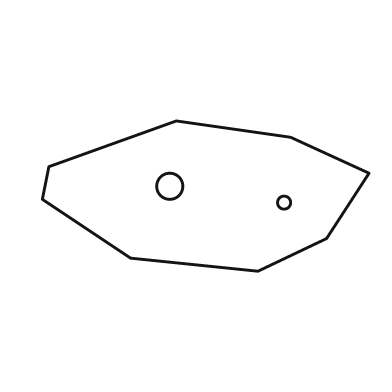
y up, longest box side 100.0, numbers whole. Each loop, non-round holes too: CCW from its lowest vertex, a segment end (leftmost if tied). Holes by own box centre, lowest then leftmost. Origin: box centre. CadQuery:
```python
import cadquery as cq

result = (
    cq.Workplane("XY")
    .moveTo(16.0, -23.0)
    .lineTo(37.0, -13.0)
    .lineTo(50.0, 7.0)
    .lineTo(26.0, 18.0)
    .lineTo(-9.0, 23.0)
    .lineTo(-48.0, 9.0)
    .lineTo(-50.0, -1.0)
    .lineTo(-23.0, -19.0)
    .close()
    .moveTo(24.0, -2.0)
    .circle(2.0)
    .moveTo(-11.0, 3.0)
    .circle(4.0)
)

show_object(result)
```